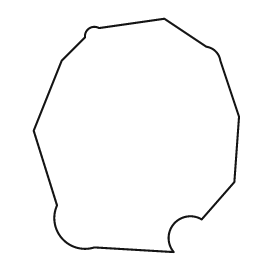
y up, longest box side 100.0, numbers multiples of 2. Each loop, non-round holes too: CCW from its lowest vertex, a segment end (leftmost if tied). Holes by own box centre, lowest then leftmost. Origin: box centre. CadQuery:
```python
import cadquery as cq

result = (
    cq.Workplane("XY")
    .moveTo(16.0, -50.0)
    .threePointArc((16.0, -38.0), (28.0, -36.0))
    .lineTo(42.0, -20.0)
    .lineTo(44.0, 8.0)
    .lineTo(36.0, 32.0)
    .threePointArc((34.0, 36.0), (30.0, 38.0))
    .lineTo(12.0, 50.0)
    .lineTo(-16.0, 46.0)
    .threePointArc((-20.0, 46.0), (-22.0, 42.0))
    .lineTo(-32.0, 32.0)
    .lineTo(-44.0, 2.0)
    .lineTo(-34.0, -30.0)
    .threePointArc((-32.0, -44.0), (-18.0, -48.0))
    .close()
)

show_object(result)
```